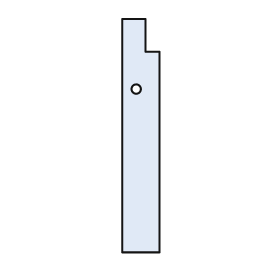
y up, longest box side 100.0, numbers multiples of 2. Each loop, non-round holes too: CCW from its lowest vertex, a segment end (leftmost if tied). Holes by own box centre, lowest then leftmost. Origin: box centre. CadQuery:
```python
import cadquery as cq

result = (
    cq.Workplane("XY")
    .moveTo(-8.0, -50.0)
    .lineTo(8.0, -50.0)
    .lineTo(8.0, 36.0)
    .lineTo(2.0, 36.0)
    .lineTo(2.0, 50.0)
    .lineTo(-8.0, 50.0)
    .close()
    .moveTo(-2.0, 20.0)
    .circle(2.0)
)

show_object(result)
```